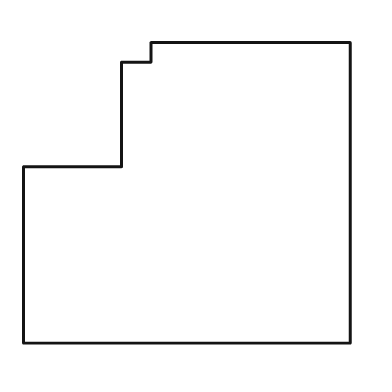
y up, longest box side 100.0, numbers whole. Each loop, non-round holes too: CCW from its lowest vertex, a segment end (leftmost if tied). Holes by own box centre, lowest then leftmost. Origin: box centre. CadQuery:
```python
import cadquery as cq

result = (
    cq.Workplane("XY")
    .moveTo(-50.0, -46.0)
    .lineTo(50.0, -46.0)
    .lineTo(50.0, 46.0)
    .lineTo(-11.0, 46.0)
    .lineTo(-11.0, 40.0)
    .lineTo(-20.0, 40.0)
    .lineTo(-20.0, 8.0)
    .lineTo(-50.0, 8.0)
    .close()
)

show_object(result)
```